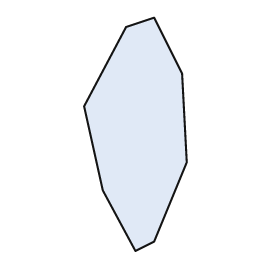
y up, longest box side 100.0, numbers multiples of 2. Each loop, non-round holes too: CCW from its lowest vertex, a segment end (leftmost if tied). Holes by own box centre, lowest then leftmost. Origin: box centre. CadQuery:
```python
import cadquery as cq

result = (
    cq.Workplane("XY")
    .moveTo(0.0, -50.0)
    .lineTo(8.0, -46.0)
    .lineTo(22.0, -12.0)
    .lineTo(20.0, 26.0)
    .lineTo(8.0, 50.0)
    .lineTo(-4.0, 46.0)
    .lineTo(-22.0, 12.0)
    .lineTo(-14.0, -24.0)
    .close()
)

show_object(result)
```